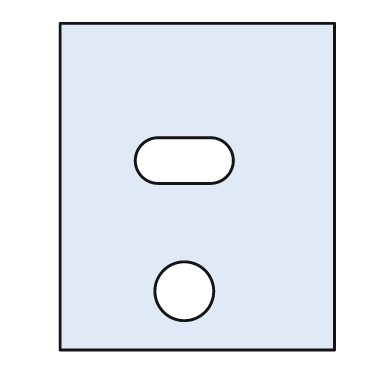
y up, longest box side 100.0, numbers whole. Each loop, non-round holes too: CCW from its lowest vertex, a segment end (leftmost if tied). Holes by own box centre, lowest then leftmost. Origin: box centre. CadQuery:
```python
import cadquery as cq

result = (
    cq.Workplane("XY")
    .moveTo(-42.0, -50.0)
    .lineTo(42.0, -50.0)
    .lineTo(42.0, 50.0)
    .lineTo(-42.0, 50.0)
    .close()
    .moveTo(-4.0, -32.0)
    .circle(9.0)
    .moveTo(-12.0, 1.0)
    .lineTo(4.0, 1.0)
    .threePointArc((11.0, 8.0), (4.0, 15.0))
    .lineTo(-12.0, 15.0)
    .threePointArc((-19.0, 8.0), (-12.0, 1.0))
    .close()
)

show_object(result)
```